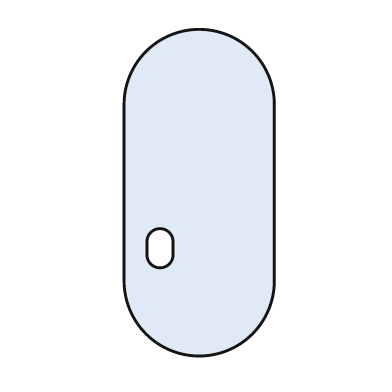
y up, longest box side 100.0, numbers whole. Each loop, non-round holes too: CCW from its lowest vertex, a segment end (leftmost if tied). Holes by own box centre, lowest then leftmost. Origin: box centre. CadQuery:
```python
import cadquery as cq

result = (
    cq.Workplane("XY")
    .moveTo(-23.0, -27.0)
    .threePointArc((0.0, -50.0), (23.0, -27.0))
    .lineTo(23.0, 27.0)
    .threePointArc((0.0, 50.0), (-23.0, 27.0))
    .close()
    .moveTo(-16.0, -19.0)
    .threePointArc((-12.0, -23.0), (-8.0, -19.0))
    .lineTo(-8.0, -15.0)
    .threePointArc((-12.0, -11.0), (-16.0, -15.0))
    .close()
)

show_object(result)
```